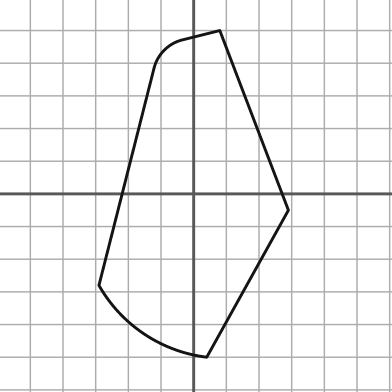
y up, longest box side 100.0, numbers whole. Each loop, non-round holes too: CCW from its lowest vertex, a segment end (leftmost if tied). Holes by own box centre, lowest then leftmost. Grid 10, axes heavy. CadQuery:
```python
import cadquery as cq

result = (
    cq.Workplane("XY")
    .moveTo(4.0, -50.0)
    .lineTo(29.0, -5.0)
    .lineTo(8.0, 50.0)
    .lineTo(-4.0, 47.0)
    .threePointArc((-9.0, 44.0), (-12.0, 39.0))
    .lineTo(-29.0, -28.0)
    .threePointArc((-15.0, -43.0), (4.0, -50.0))
    .close()
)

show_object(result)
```